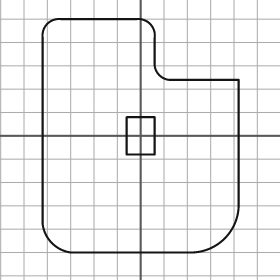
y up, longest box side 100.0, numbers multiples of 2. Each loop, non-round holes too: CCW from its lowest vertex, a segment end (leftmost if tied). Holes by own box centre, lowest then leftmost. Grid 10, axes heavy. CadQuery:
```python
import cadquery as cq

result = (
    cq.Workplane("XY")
    .moveTo(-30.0, -50.0)
    .lineTo(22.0, -50.0)
    .threePointArc((36.0, -44.0), (42.0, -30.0))
    .lineTo(42.0, 24.0)
    .lineTo(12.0, 24.0)
    .threePointArc((8.0, 26.0), (6.0, 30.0))
    .lineTo(6.0, 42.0)
    .threePointArc((4.0, 48.0), (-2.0, 50.0))
    .lineTo(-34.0, 50.0)
    .threePointArc((-40.0, 48.0), (-42.0, 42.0))
    .lineTo(-42.0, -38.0)
    .threePointArc((-38.0, -46.0), (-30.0, -50.0))
    .close()
    .moveTo(-6.0, -8.0)
    .lineTo(6.0, -8.0)
    .lineTo(6.0, 8.0)
    .lineTo(-6.0, 8.0)
    .close()
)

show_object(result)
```